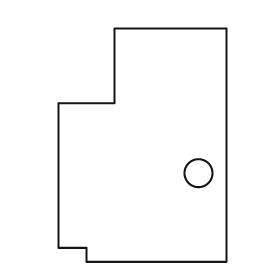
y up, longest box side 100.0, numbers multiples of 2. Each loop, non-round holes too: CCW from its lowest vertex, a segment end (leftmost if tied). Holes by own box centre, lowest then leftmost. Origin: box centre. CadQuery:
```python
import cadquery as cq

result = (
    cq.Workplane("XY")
    .moveTo(-24.0, -50.0)
    .lineTo(36.0, -50.0)
    .lineTo(36.0, 50.0)
    .lineTo(-12.0, 50.0)
    .lineTo(-12.0, 18.0)
    .lineTo(-36.0, 18.0)
    .lineTo(-36.0, -44.0)
    .lineTo(-24.0, -44.0)
    .close()
    .moveTo(24.0, -12.0)
    .circle(6.0)
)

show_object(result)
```